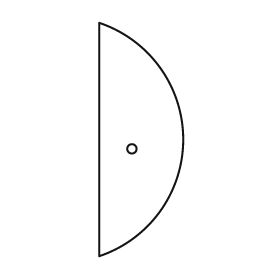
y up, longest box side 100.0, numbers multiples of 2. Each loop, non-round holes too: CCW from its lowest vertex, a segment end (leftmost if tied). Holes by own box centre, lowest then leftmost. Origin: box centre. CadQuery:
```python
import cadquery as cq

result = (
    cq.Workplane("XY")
    .moveTo(-18.0, -50.0)
    .threePointArc((18.0, 0.0), (-18.0, 50.0))
    .close()
    .moveTo(-4.0, -4.0)
    .circle(2.0)
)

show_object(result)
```